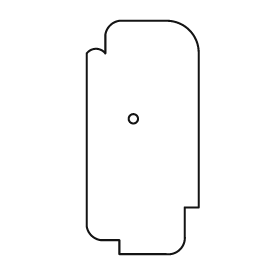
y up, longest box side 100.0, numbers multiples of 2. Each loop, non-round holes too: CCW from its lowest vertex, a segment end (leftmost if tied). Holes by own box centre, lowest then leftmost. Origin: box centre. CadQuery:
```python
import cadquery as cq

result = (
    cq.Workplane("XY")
    .moveTo(-10.0, -50.0)
    .lineTo(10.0, -50.0)
    .threePointArc((16.0, -48.0), (18.0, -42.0))
    .lineTo(18.0, -30.0)
    .lineTo(24.0, -30.0)
    .lineTo(24.0, 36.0)
    .threePointArc((20.0, 46.0), (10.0, 50.0))
    .lineTo(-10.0, 50.0)
    .threePointArc((-14.0, 48.0), (-16.0, 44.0))
    .lineTo(-16.0, 36.0)
    .threePointArc((-20.0, 38.0), (-24.0, 36.0))
    .lineTo(-24.0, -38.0)
    .threePointArc((-22.0, -42.0), (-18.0, -44.0))
    .lineTo(-10.0, -44.0)
    .close()
    .moveTo(-4.0, 8.0)
    .circle(2.0)
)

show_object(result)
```